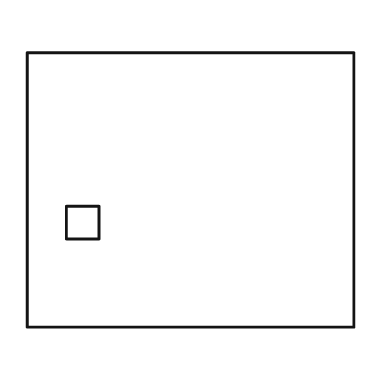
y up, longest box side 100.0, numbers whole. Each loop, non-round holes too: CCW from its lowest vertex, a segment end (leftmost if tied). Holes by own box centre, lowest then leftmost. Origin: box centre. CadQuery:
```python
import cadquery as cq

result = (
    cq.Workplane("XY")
    .moveTo(-50.0, -42.0)
    .lineTo(50.0, -42.0)
    .lineTo(50.0, 42.0)
    .lineTo(-50.0, 42.0)
    .close()
    .moveTo(-38.0, -15.0)
    .lineTo(-28.0, -15.0)
    .lineTo(-28.0, -5.0)
    .lineTo(-38.0, -5.0)
    .close()
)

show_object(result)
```